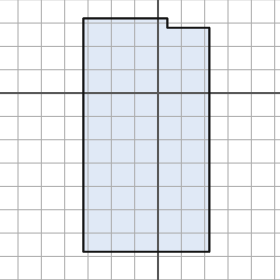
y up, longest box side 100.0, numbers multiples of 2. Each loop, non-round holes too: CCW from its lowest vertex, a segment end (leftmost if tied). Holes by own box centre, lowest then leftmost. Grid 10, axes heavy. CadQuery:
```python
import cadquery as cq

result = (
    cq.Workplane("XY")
    .moveTo(-32.0, -68.0)
    .lineTo(22.0, -68.0)
    .lineTo(22.0, 28.0)
    .lineTo(4.0, 28.0)
    .lineTo(4.0, 32.0)
    .lineTo(-32.0, 32.0)
    .close()
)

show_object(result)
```